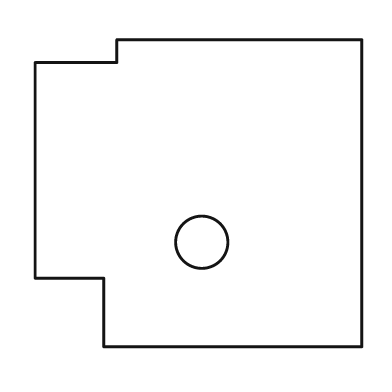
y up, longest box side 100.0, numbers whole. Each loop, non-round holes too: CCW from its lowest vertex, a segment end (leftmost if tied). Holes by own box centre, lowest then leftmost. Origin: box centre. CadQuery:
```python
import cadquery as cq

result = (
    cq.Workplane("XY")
    .moveTo(-29.0, -47.0)
    .lineTo(50.0, -47.0)
    .lineTo(50.0, 47.0)
    .lineTo(-25.0, 47.0)
    .lineTo(-25.0, 40.0)
    .lineTo(-50.0, 40.0)
    .lineTo(-50.0, -26.0)
    .lineTo(-29.0, -26.0)
    .close()
    .moveTo(1.0, -15.0)
    .circle(8.0)
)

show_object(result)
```